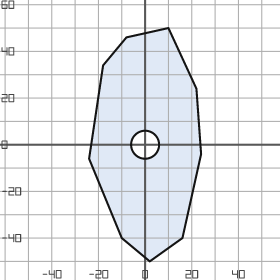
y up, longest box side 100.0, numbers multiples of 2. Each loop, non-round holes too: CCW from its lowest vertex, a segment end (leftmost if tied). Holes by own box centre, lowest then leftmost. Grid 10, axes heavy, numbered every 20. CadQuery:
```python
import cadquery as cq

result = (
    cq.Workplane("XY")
    .moveTo(2.0, -50.0)
    .lineTo(16.0, -40.0)
    .lineTo(24.0, -4.0)
    .lineTo(22.0, 24.0)
    .lineTo(10.0, 50.0)
    .lineTo(-8.0, 46.0)
    .lineTo(-18.0, 34.0)
    .lineTo(-24.0, -6.0)
    .lineTo(-10.0, -40.0)
    .close()
    .moveTo(0.0, 0.0)
    .circle(6.0)
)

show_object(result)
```